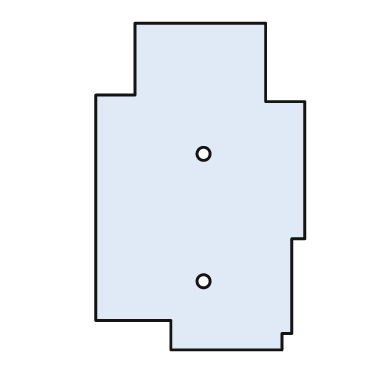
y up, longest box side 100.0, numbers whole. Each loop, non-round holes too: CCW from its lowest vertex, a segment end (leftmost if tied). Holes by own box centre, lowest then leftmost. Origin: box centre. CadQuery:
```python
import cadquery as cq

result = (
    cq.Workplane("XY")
    .moveTo(-9.0, -50.0)
    .lineTo(25.0, -50.0)
    .lineTo(25.0, -45.0)
    .lineTo(28.0, -45.0)
    .lineTo(28.0, -16.0)
    .lineTo(32.0, -16.0)
    .lineTo(32.0, 26.0)
    .lineTo(20.0, 26.0)
    .lineTo(20.0, 50.0)
    .lineTo(-20.0, 50.0)
    .lineTo(-20.0, 28.0)
    .lineTo(-32.0, 28.0)
    .lineTo(-32.0, -41.0)
    .lineTo(-9.0, -41.0)
    .close()
    .moveTo(1.0, -29.0)
    .circle(2.0)
    .moveTo(1.0, 10.0)
    .circle(2.0)
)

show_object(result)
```